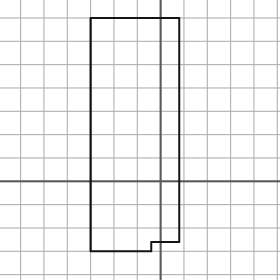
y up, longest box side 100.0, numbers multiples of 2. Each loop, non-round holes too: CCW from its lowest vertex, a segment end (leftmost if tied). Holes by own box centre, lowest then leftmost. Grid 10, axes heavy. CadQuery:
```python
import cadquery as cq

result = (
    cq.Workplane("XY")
    .moveTo(-30.0, -30.0)
    .lineTo(-4.0, -30.0)
    .lineTo(-4.0, -26.0)
    .lineTo(8.0, -26.0)
    .lineTo(8.0, 70.0)
    .lineTo(-30.0, 70.0)
    .close()
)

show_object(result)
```